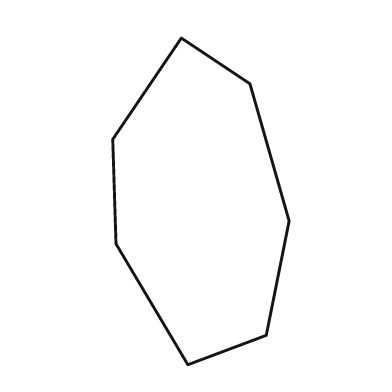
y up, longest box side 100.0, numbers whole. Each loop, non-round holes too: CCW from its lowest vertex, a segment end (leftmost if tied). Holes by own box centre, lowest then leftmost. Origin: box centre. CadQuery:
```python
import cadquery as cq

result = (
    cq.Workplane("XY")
    .moveTo(-4.0, -50.0)
    .lineTo(20.0, -41.0)
    .lineTo(27.0, -6.0)
    .lineTo(15.0, 36.0)
    .lineTo(-6.0, 50.0)
    .lineTo(-27.0, 19.0)
    .lineTo(-26.0, -13.0)
    .close()
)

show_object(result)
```